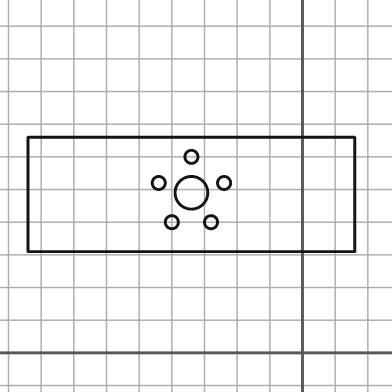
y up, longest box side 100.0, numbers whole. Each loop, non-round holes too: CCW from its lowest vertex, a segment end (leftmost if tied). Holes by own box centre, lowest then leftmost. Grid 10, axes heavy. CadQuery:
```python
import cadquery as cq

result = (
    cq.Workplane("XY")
    .moveTo(-84.0, 31.0)
    .lineTo(16.0, 31.0)
    .lineTo(16.0, 66.0)
    .lineTo(-84.0, 66.0)
    .close()
    .moveTo(-40.0, 40.0)
    .circle(2.0)
    .moveTo(-28.0, 40.0)
    .circle(2.0)
    .moveTo(-34.0, 49.0)
    .circle(5.0)
    .moveTo(-44.0, 52.0)
    .circle(2.0)
    .moveTo(-24.0, 52.0)
    .circle(2.0)
    .moveTo(-34.0, 60.0)
    .circle(2.0)
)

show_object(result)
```